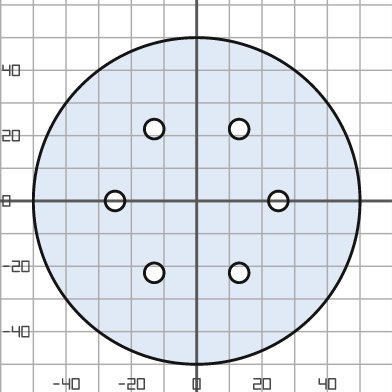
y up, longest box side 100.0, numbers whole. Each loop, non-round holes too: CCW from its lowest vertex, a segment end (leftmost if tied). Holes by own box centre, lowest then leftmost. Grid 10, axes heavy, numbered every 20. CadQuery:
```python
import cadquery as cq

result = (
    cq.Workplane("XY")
    .moveTo(0.0, 0.0)
    .circle(50.0)
    .moveTo(-13.0, -22.0)
    .circle(3.0)
    .moveTo(13.0, -22.0)
    .circle(3.0)
    .moveTo(-25.0, 0.0)
    .circle(3.0)
    .moveTo(25.0, 0.0)
    .circle(3.0)
    .moveTo(-13.0, 22.0)
    .circle(3.0)
    .moveTo(13.0, 22.0)
    .circle(3.0)
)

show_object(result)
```